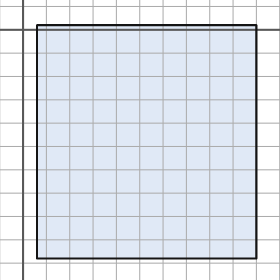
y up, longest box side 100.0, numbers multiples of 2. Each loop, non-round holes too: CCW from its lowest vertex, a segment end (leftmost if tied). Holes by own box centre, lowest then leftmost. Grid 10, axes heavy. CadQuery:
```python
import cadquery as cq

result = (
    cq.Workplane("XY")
    .moveTo(6.0, -98.0)
    .lineTo(100.0, -98.0)
    .lineTo(100.0, 2.0)
    .lineTo(6.0, 2.0)
    .close()
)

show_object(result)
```